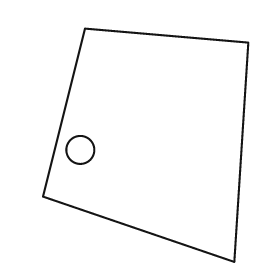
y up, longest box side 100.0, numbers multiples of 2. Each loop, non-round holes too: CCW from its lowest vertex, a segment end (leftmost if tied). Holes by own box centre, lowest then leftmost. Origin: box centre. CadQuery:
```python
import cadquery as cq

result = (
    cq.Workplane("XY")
    .moveTo(38.0, -50.0)
    .lineTo(44.0, 44.0)
    .lineTo(-26.0, 50.0)
    .lineTo(-44.0, -22.0)
    .close()
    .moveTo(-28.0, -2.0)
    .circle(6.0)
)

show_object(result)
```